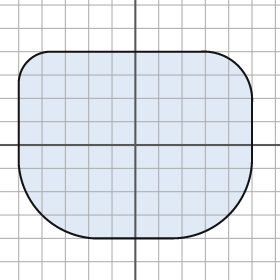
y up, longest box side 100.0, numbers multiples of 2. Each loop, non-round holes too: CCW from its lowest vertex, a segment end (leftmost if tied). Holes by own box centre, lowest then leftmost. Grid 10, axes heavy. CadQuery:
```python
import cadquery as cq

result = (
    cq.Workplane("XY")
    .moveTo(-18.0, -40.0)
    .lineTo(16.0, -40.0)
    .threePointArc((40.0, -30.0), (50.0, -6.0))
    .lineTo(50.0, 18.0)
    .threePointArc((44.0, 34.0), (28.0, 40.0))
    .lineTo(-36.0, 40.0)
    .threePointArc((-46.0, 36.0), (-50.0, 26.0))
    .lineTo(-50.0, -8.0)
    .threePointArc((-40.0, -30.0), (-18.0, -40.0))
    .close()
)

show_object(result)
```